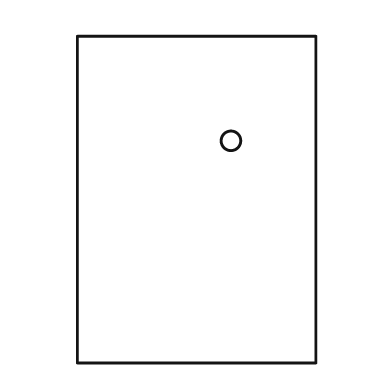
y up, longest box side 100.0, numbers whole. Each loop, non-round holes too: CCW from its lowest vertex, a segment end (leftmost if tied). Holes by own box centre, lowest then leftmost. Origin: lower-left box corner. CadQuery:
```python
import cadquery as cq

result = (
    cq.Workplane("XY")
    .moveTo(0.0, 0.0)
    .lineTo(73.0, 0.0)
    .lineTo(73.0, 100.0)
    .lineTo(0.0, 100.0)
    .close()
    .moveTo(47.0, 68.0)
    .circle(3.0)
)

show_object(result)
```